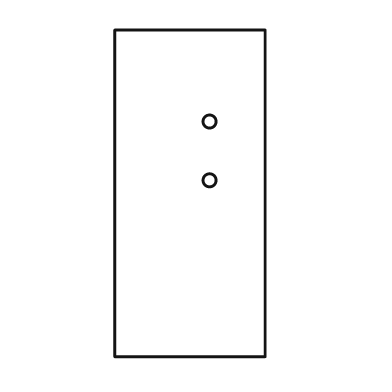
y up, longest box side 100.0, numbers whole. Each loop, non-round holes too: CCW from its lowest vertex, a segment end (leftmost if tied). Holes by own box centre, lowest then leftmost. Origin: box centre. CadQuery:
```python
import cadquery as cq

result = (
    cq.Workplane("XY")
    .moveTo(-23.0, -50.0)
    .lineTo(23.0, -50.0)
    .lineTo(23.0, 50.0)
    .lineTo(-23.0, 50.0)
    .close()
    .moveTo(6.0, 4.0)
    .circle(2.0)
    .moveTo(6.0, 22.0)
    .circle(2.0)
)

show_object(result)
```